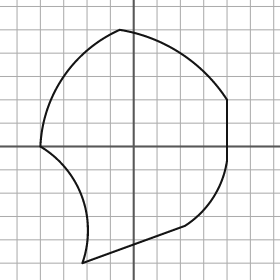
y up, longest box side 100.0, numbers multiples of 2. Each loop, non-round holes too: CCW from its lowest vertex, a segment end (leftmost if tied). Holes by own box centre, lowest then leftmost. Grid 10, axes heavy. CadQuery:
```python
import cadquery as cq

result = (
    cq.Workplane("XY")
    .moveTo(-22.0, -50.0)
    .lineTo(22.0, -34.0)
    .threePointArc((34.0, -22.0), (40.0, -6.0))
    .lineTo(40.0, 20.0)
    .threePointArc((20.0, 40.0), (-6.0, 50.0))
    .threePointArc((-30.0, 30.0), (-40.0, 0.0))
    .threePointArc((-22.0, -22.0), (-22.0, -50.0))
    .close()
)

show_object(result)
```